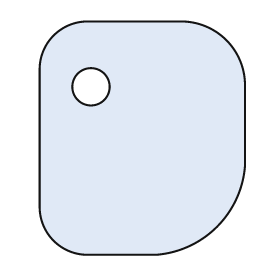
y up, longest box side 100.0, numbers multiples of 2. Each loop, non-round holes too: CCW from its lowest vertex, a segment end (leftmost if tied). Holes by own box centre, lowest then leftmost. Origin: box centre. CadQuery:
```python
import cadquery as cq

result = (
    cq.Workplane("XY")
    .moveTo(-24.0, -50.0)
    .lineTo(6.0, -50.0)
    .threePointArc((32.0, -38.0), (44.0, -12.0))
    .lineTo(44.0, 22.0)
    .threePointArc((36.0, 42.0), (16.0, 50.0))
    .lineTo(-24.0, 50.0)
    .threePointArc((-38.0, 44.0), (-44.0, 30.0))
    .lineTo(-44.0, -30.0)
    .threePointArc((-38.0, -44.0), (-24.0, -50.0))
    .close()
    .moveTo(-22.0, 22.0)
    .circle(8.0)
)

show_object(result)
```